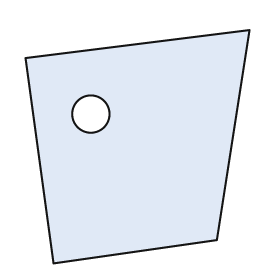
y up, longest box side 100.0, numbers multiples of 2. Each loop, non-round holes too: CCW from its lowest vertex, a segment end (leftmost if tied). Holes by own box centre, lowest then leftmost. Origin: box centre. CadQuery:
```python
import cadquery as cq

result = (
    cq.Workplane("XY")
    .moveTo(-36.0, -50.0)
    .lineTo(34.0, -40.0)
    .lineTo(48.0, 50.0)
    .lineTo(-48.0, 38.0)
    .close()
    .moveTo(-20.0, 14.0)
    .circle(8.0)
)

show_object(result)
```